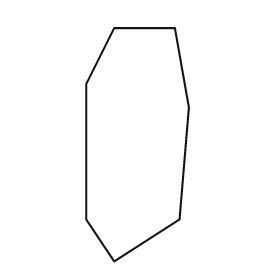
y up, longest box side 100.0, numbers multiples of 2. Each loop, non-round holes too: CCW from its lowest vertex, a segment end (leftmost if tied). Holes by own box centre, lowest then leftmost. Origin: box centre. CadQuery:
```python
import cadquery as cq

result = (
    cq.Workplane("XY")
    .moveTo(-10.0, -50.0)
    .lineTo(18.0, -32.0)
    .lineTo(22.0, 16.0)
    .lineTo(16.0, 50.0)
    .lineTo(-10.0, 50.0)
    .lineTo(-22.0, 26.0)
    .lineTo(-22.0, -32.0)
    .close()
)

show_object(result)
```